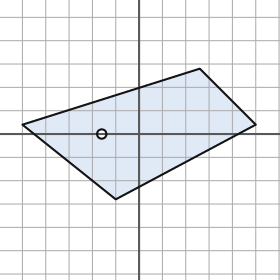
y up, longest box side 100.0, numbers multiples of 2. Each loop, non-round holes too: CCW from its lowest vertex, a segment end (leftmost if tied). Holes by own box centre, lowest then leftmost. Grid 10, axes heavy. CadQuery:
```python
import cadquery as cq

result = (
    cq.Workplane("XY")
    .moveTo(-10.0, -28.0)
    .lineTo(50.0, 4.0)
    .lineTo(26.0, 28.0)
    .lineTo(-50.0, 4.0)
    .close()
    .moveTo(-16.0, 0.0)
    .circle(2.0)
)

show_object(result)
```